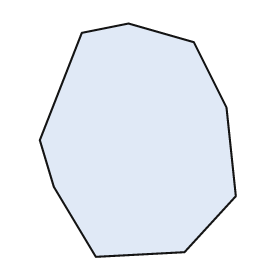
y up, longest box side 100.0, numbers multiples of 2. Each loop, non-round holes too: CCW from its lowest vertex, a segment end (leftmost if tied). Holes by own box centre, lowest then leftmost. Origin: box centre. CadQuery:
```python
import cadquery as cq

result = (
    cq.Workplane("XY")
    .moveTo(-18.0, -50.0)
    .lineTo(20.0, -48.0)
    .lineTo(42.0, -24.0)
    .lineTo(38.0, 14.0)
    .lineTo(24.0, 42.0)
    .lineTo(-4.0, 50.0)
    .lineTo(-24.0, 46.0)
    .lineTo(-42.0, 0.0)
    .lineTo(-36.0, -20.0)
    .close()
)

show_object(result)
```